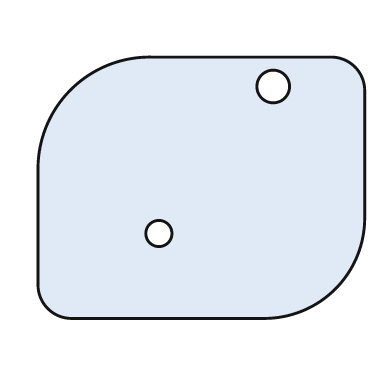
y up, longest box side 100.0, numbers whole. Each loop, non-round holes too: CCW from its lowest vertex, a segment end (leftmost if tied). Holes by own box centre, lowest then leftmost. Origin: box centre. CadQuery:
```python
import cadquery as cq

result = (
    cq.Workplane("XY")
    .moveTo(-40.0, -40.0)
    .lineTo(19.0, -40.0)
    .threePointArc((41.0, -31.0), (50.0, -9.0))
    .lineTo(50.0, 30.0)
    .threePointArc((47.0, 37.0), (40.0, 40.0))
    .lineTo(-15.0, 40.0)
    .threePointArc((-40.0, 30.0), (-50.0, 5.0))
    .lineTo(-50.0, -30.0)
    .threePointArc((-47.0, -37.0), (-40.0, -40.0))
    .close()
    .moveTo(-13.0, -14.0)
    .circle(4.0)
    .moveTo(22.0, 31.0)
    .circle(5.0)
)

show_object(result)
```